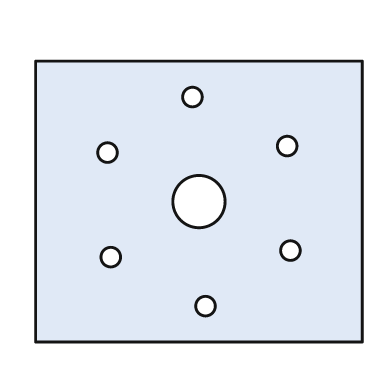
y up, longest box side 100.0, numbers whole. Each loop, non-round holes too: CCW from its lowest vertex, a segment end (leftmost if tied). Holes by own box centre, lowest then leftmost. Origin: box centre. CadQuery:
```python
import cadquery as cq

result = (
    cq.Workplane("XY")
    .moveTo(-50.0, -43.0)
    .lineTo(50.0, -43.0)
    .lineTo(50.0, 43.0)
    .lineTo(-50.0, 43.0)
    .close()
    .moveTo(2.0, -32.0)
    .circle(3.0)
    .moveTo(-27.0, -17.0)
    .circle(3.0)
    .moveTo(28.0, -15.0)
    .circle(3.0)
    .moveTo(0.0, 0.0)
    .circle(8.0)
    .moveTo(-28.0, 15.0)
    .circle(3.0)
    .moveTo(27.0, 17.0)
    .circle(3.0)
    .moveTo(-2.0, 32.0)
    .circle(3.0)
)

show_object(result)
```